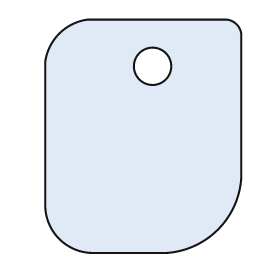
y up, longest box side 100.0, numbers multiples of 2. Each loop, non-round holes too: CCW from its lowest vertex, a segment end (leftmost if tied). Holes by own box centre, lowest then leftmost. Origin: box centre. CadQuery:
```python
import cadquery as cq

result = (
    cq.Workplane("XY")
    .moveTo(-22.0, -50.0)
    .lineTo(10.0, -50.0)
    .threePointArc((32.0, -40.0), (42.0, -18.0))
    .lineTo(42.0, 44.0)
    .threePointArc((40.0, 48.0), (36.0, 50.0))
    .lineTo(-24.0, 50.0)
    .threePointArc((-36.0, 44.0), (-42.0, 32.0))
    .lineTo(-42.0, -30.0)
    .threePointArc((-36.0, -44.0), (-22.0, -50.0))
    .close()
    .moveTo(4.0, 30.0)
    .circle(8.0)
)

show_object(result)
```